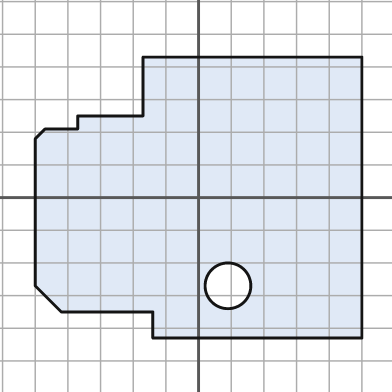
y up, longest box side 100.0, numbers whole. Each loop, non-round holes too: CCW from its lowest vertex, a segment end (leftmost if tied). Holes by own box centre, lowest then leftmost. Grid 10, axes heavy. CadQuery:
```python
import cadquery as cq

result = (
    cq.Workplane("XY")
    .moveTo(-14.0, -43.0)
    .lineTo(50.0, -43.0)
    .lineTo(50.0, 43.0)
    .lineTo(-17.0, 43.0)
    .lineTo(-17.0, 25.0)
    .lineTo(-37.0, 25.0)
    .lineTo(-37.0, 21.0)
    .lineTo(-47.0, 21.0)
    .lineTo(-50.0, 18.0)
    .lineTo(-50.0, -27.0)
    .lineTo(-42.0, -35.0)
    .lineTo(-14.0, -35.0)
    .close()
    .moveTo(9.0, -27.0)
    .circle(7.0)
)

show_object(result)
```